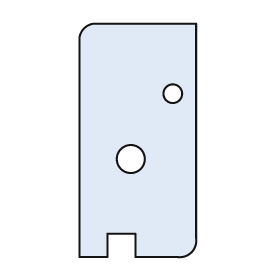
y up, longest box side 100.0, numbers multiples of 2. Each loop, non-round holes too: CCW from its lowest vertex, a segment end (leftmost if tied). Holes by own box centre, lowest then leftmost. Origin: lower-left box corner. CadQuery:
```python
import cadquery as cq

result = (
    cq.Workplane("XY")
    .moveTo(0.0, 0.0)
    .lineTo(12.0, 0.0)
    .lineTo(12.0, 10.0)
    .lineTo(24.0, 10.0)
    .lineTo(24.0, 0.0)
    .lineTo(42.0, 0.0)
    .threePointArc((48.0, 2.0), (50.0, 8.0))
    .lineTo(50.0, 100.0)
    .lineTo(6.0, 100.0)
    .threePointArc((2.0, 98.0), (0.0, 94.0))
    .close()
    .moveTo(22.0, 42.0)
    .circle(6.0)
    .moveTo(40.0, 70.0)
    .circle(4.0)
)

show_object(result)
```